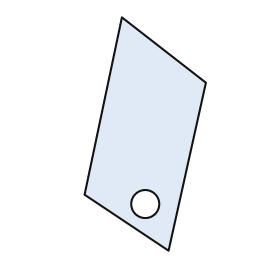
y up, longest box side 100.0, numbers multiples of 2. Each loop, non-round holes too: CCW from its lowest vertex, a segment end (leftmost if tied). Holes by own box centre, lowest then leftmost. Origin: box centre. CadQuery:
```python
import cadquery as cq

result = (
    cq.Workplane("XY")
    .moveTo(10.0, -50.0)
    .lineTo(26.0, 22.0)
    .lineTo(-10.0, 50.0)
    .lineTo(-26.0, -26.0)
    .close()
    .moveTo(0.0, -30.0)
    .circle(6.0)
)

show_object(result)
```